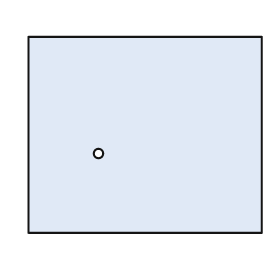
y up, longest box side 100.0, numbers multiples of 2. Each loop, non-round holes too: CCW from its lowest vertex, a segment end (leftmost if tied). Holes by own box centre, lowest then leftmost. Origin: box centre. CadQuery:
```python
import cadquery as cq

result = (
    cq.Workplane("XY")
    .moveTo(-50.0, -42.0)
    .lineTo(50.0, -42.0)
    .lineTo(50.0, 42.0)
    .lineTo(-50.0, 42.0)
    .close()
    .moveTo(-20.0, -8.0)
    .circle(2.0)
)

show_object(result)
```